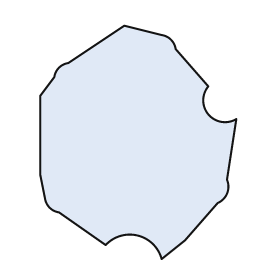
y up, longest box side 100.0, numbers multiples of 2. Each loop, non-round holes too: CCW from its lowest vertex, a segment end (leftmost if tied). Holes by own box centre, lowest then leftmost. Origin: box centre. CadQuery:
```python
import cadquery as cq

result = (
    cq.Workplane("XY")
    .moveTo(10.0, -50.0)
    .lineTo(20.0, -42.0)
    .lineTo(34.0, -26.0)
    .threePointArc((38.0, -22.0), (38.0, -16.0))
    .lineTo(42.0, 10.0)
    .threePointArc((30.0, 12.0), (30.0, 24.0))
    .lineTo(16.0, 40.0)
    .threePointArc((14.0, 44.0), (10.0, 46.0))
    .lineTo(-6.0, 50.0)
    .lineTo(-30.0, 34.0)
    .threePointArc((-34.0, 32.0), (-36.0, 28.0))
    .lineTo(-42.0, 20.0)
    .lineTo(-42.0, -14.0)
    .lineTo(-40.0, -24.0)
    .threePointArc((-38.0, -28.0), (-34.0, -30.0))
    .lineTo(-14.0, -44.0)
    .threePointArc((0.0, -40.0), (10.0, -50.0))
    .close()
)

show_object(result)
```